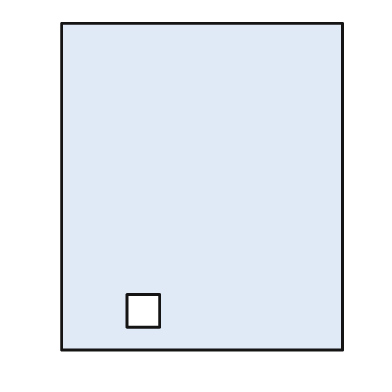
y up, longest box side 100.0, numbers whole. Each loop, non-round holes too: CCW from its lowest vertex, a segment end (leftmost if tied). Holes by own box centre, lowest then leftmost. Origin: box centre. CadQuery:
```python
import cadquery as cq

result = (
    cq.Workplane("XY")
    .moveTo(-43.0, -50.0)
    .lineTo(43.0, -50.0)
    .lineTo(43.0, 50.0)
    .lineTo(-43.0, 50.0)
    .close()
    .moveTo(-23.0, -43.0)
    .lineTo(-13.0, -43.0)
    .lineTo(-13.0, -33.0)
    .lineTo(-23.0, -33.0)
    .close()
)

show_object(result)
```